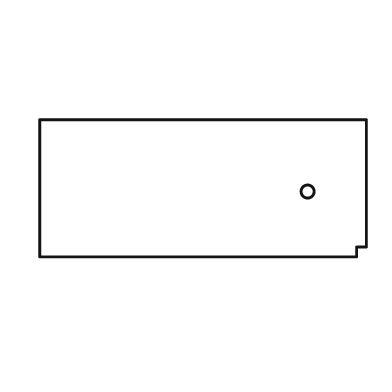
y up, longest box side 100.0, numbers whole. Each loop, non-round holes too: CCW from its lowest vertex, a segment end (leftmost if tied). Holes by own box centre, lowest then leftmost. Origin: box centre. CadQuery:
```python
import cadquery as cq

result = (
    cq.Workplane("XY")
    .moveTo(-50.0, -21.0)
    .lineTo(47.0, -21.0)
    .lineTo(47.0, -18.0)
    .lineTo(50.0, -18.0)
    .lineTo(50.0, 21.0)
    .lineTo(-50.0, 21.0)
    .close()
    .moveTo(32.0, -1.0)
    .circle(2.0)
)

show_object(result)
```